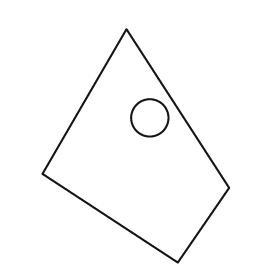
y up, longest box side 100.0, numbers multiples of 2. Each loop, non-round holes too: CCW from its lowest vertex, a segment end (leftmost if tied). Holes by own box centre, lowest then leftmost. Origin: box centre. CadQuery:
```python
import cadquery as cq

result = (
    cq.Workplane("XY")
    .moveTo(18.0, -50.0)
    .lineTo(40.0, -18.0)
    .lineTo(-4.0, 50.0)
    .lineTo(-40.0, -12.0)
    .close()
    .moveTo(6.0, 12.0)
    .circle(8.0)
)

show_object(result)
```